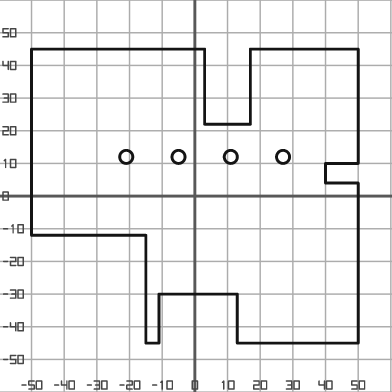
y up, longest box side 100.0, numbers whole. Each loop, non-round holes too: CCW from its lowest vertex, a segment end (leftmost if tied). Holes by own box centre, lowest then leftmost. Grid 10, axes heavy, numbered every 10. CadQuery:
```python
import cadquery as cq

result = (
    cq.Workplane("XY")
    .moveTo(-15.0, -45.0)
    .lineTo(-11.0, -45.0)
    .lineTo(-11.0, -30.0)
    .lineTo(13.0, -30.0)
    .lineTo(13.0, -45.0)
    .lineTo(50.0, -45.0)
    .lineTo(50.0, 4.0)
    .lineTo(40.0, 4.0)
    .lineTo(40.0, 10.0)
    .lineTo(50.0, 10.0)
    .lineTo(50.0, 45.0)
    .lineTo(17.0, 45.0)
    .lineTo(17.0, 22.0)
    .lineTo(3.0, 22.0)
    .lineTo(3.0, 45.0)
    .lineTo(-50.0, 45.0)
    .lineTo(-50.0, -12.0)
    .lineTo(-15.0, -12.0)
    .close()
    .moveTo(-21.0, 12.0)
    .circle(2.0)
    .moveTo(-5.0, 12.0)
    .circle(2.0)
    .moveTo(11.0, 12.0)
    .circle(2.0)
    .moveTo(27.0, 12.0)
    .circle(2.0)
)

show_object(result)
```